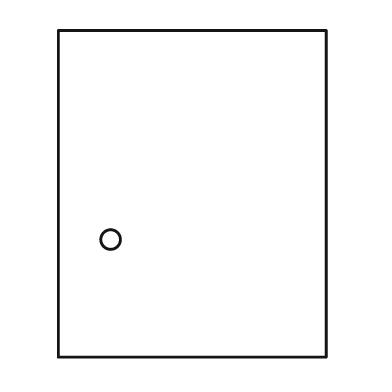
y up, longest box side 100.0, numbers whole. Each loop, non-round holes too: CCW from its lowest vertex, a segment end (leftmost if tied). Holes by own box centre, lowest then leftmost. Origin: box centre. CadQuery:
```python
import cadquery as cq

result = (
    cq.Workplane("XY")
    .moveTo(-41.0, -50.0)
    .lineTo(41.0, -50.0)
    .lineTo(41.0, 50.0)
    .lineTo(-41.0, 50.0)
    .close()
    .moveTo(-25.0, -14.0)
    .circle(3.0)
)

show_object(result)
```